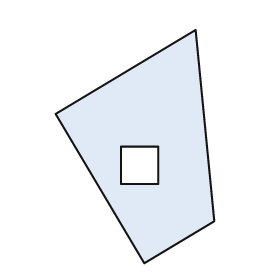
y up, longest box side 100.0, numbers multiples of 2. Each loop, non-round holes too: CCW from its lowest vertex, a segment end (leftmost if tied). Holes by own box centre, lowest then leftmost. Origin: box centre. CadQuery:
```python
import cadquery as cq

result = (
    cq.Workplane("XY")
    .moveTo(4.0, -50.0)
    .lineTo(34.0, -32.0)
    .lineTo(26.0, 50.0)
    .lineTo(-34.0, 14.0)
    .close()
    .moveTo(-6.0, -16.0)
    .lineTo(10.0, -16.0)
    .lineTo(10.0, 0.0)
    .lineTo(-6.0, 0.0)
    .close()
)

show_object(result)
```